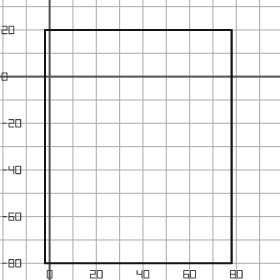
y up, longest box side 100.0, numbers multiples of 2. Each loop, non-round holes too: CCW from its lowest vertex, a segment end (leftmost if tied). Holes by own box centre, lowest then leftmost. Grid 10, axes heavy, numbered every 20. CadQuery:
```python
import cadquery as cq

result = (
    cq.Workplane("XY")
    .moveTo(-2.0, -80.0)
    .lineTo(78.0, -80.0)
    .lineTo(78.0, 20.0)
    .lineTo(-2.0, 20.0)
    .close()
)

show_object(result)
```